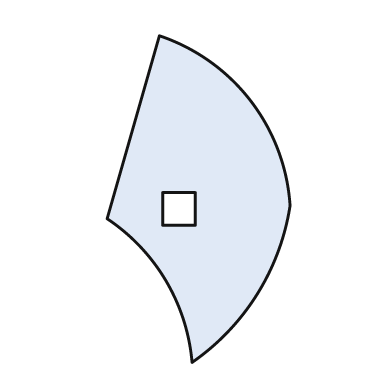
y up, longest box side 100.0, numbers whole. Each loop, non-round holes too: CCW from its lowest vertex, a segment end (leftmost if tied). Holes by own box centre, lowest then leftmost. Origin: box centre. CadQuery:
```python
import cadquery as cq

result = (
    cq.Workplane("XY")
    .moveTo(-2.0, -50.0)
    .threePointArc((18.0, -29.0), (28.0, -2.0))
    .threePointArc((16.0, 30.0), (-12.0, 50.0))
    .lineTo(-28.0, -6.0)
    .threePointArc((-10.0, -25.0), (-2.0, -50.0))
    .close()
    .moveTo(-11.0, -8.0)
    .lineTo(-1.0, -8.0)
    .lineTo(-1.0, 2.0)
    .lineTo(-11.0, 2.0)
    .close()
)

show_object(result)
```